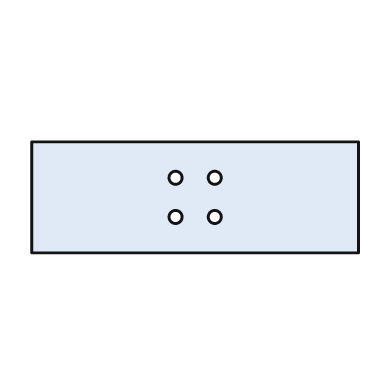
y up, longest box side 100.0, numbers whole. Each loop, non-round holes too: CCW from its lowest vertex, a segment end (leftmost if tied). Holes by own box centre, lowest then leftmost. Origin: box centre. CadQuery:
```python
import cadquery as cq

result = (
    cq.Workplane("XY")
    .moveTo(-50.0, -17.0)
    .lineTo(50.0, -17.0)
    .lineTo(50.0, 17.0)
    .lineTo(-50.0, 17.0)
    .close()
    .moveTo(-6.0, -6.0)
    .circle(2.0)
    .moveTo(6.0, -6.0)
    .circle(2.0)
    .moveTo(-6.0, 6.0)
    .circle(2.0)
    .moveTo(6.0, 6.0)
    .circle(2.0)
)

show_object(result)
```